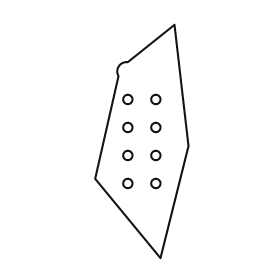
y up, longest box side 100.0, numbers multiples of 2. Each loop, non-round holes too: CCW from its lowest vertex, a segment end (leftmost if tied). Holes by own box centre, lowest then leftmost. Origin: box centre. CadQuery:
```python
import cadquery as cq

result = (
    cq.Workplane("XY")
    .moveTo(8.0, -50.0)
    .lineTo(20.0, -2.0)
    .lineTo(14.0, 50.0)
    .lineTo(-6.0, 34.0)
    .threePointArc((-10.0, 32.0), (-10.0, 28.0))
    .lineTo(-20.0, -16.0)
    .close()
    .moveTo(-6.0, -18.0)
    .circle(2.0)
    .moveTo(6.0, -18.0)
    .circle(2.0)
    .moveTo(-6.0, -6.0)
    .circle(2.0)
    .moveTo(6.0, -6.0)
    .circle(2.0)
    .moveTo(-6.0, 6.0)
    .circle(2.0)
    .moveTo(6.0, 6.0)
    .circle(2.0)
    .moveTo(-6.0, 18.0)
    .circle(2.0)
    .moveTo(6.0, 18.0)
    .circle(2.0)
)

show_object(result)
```